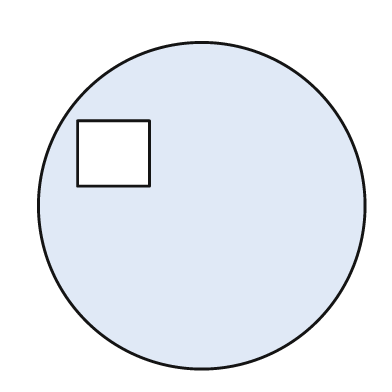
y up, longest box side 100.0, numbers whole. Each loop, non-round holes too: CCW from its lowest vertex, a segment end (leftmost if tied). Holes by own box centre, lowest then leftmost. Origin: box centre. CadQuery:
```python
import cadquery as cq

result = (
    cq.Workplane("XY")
    .moveTo(0.0, 0.0)
    .circle(50.0)
    .moveTo(-38.0, 6.0)
    .lineTo(-16.0, 6.0)
    .lineTo(-16.0, 26.0)
    .lineTo(-38.0, 26.0)
    .close()
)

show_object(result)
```